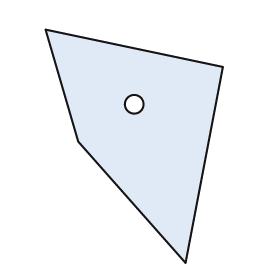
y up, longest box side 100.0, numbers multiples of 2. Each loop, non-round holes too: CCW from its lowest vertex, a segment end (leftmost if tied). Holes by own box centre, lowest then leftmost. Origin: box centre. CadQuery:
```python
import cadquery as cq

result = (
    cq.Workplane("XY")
    .moveTo(22.0, -50.0)
    .lineTo(38.0, 34.0)
    .lineTo(-38.0, 50.0)
    .lineTo(-24.0, 2.0)
    .close()
    .moveTo(0.0, 18.0)
    .circle(4.0)
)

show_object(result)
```